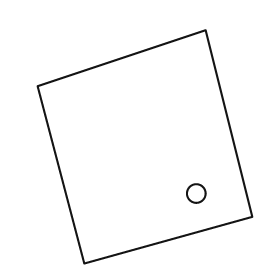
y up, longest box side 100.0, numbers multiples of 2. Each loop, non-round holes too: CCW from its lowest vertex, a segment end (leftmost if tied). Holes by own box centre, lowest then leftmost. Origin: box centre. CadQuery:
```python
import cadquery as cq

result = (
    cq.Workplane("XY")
    .moveTo(-26.0, -50.0)
    .lineTo(46.0, -30.0)
    .lineTo(26.0, 50.0)
    .lineTo(-46.0, 26.0)
    .close()
    .moveTo(22.0, -20.0)
    .circle(4.0)
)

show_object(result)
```